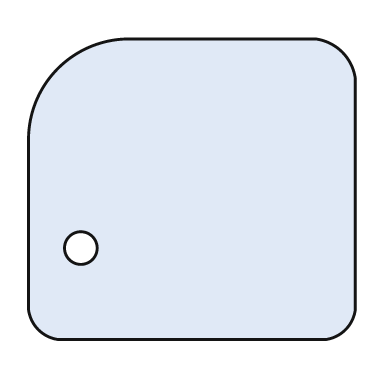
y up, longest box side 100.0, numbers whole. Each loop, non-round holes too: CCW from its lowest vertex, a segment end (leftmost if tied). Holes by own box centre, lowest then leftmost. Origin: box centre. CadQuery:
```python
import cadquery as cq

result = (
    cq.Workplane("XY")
    .moveTo(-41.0, -46.0)
    .lineTo(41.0, -46.0)
    .threePointArc((47.0, -43.0), (50.0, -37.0))
    .lineTo(50.0, 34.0)
    .threePointArc((46.0, 42.0), (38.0, 46.0))
    .lineTo(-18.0, 46.0)
    .threePointArc((-41.0, 37.0), (-50.0, 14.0))
    .lineTo(-50.0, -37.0)
    .threePointArc((-47.0, -43.0), (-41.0, -46.0))
    .close()
    .moveTo(-34.0, -18.0)
    .circle(5.0)
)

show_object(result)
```